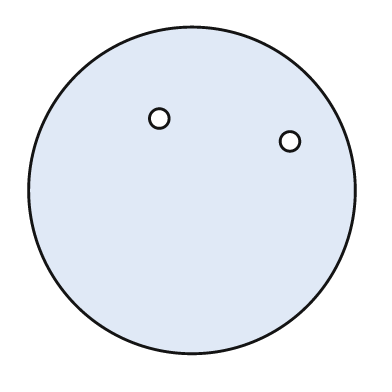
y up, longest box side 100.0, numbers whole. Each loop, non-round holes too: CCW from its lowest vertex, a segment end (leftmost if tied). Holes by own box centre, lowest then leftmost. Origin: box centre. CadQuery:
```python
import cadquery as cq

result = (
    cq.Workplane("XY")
    .moveTo(0.0, 0.0)
    .circle(50.0)
    .moveTo(30.0, 15.0)
    .circle(3.0)
    .moveTo(-10.0, 22.0)
    .circle(3.0)
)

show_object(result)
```